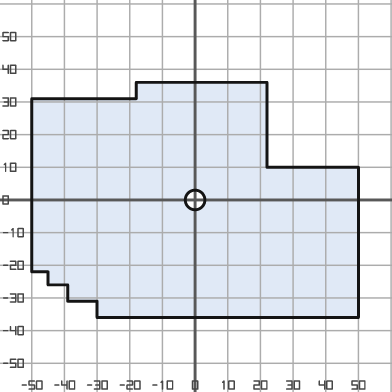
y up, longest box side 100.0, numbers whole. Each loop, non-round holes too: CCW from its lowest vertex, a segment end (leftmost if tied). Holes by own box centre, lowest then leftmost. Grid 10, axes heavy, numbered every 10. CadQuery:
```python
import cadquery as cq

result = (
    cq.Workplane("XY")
    .moveTo(-30.0, -36.0)
    .lineTo(50.0, -36.0)
    .lineTo(50.0, 10.0)
    .lineTo(22.0, 10.0)
    .lineTo(22.0, 36.0)
    .lineTo(-18.0, 36.0)
    .lineTo(-18.0, 31.0)
    .lineTo(-50.0, 31.0)
    .lineTo(-50.0, -22.0)
    .lineTo(-45.0, -22.0)
    .lineTo(-45.0, -26.0)
    .lineTo(-39.0, -26.0)
    .lineTo(-39.0, -31.0)
    .lineTo(-30.0, -31.0)
    .close()
    .moveTo(0.0, 0.0)
    .circle(3.0)
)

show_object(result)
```